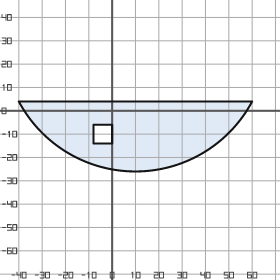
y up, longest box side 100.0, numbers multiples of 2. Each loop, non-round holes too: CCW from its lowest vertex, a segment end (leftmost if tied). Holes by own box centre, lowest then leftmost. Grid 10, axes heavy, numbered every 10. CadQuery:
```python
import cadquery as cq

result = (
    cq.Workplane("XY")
    .moveTo(-40.0, 4.0)
    .threePointArc((10.0, -26.0), (60.0, 4.0))
    .close()
    .moveTo(-8.0, -14.0)
    .lineTo(0.0, -14.0)
    .lineTo(0.0, -6.0)
    .lineTo(-8.0, -6.0)
    .close()
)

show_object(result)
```